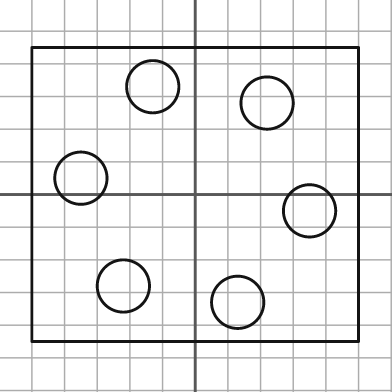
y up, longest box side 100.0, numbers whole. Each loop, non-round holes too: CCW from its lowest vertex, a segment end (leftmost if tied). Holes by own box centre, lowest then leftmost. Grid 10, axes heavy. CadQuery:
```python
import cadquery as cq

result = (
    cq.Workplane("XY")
    .moveTo(-50.0, -45.0)
    .lineTo(50.0, -45.0)
    .lineTo(50.0, 45.0)
    .lineTo(-50.0, 45.0)
    .close()
    .moveTo(13.0, -33.0)
    .circle(8.0)
    .moveTo(-22.0, -28.0)
    .circle(8.0)
    .moveTo(35.0, -5.0)
    .circle(8.0)
    .moveTo(-35.0, 5.0)
    .circle(8.0)
    .moveTo(22.0, 28.0)
    .circle(8.0)
    .moveTo(-13.0, 33.0)
    .circle(8.0)
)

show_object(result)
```